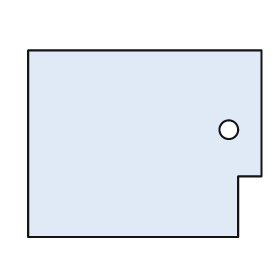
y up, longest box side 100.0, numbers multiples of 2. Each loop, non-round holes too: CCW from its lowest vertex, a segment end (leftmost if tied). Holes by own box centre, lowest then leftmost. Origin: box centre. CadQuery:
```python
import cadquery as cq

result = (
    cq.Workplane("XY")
    .moveTo(-50.0, -40.0)
    .lineTo(40.0, -40.0)
    .lineTo(40.0, -14.0)
    .lineTo(50.0, -14.0)
    .lineTo(50.0, 40.0)
    .lineTo(-50.0, 40.0)
    .close()
    .moveTo(36.0, 6.0)
    .circle(4.0)
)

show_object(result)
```